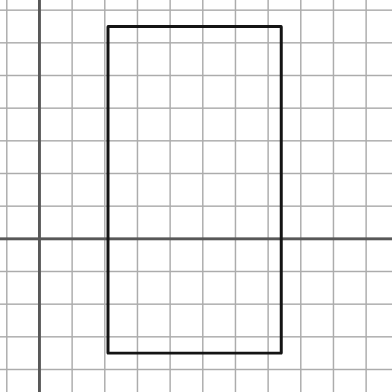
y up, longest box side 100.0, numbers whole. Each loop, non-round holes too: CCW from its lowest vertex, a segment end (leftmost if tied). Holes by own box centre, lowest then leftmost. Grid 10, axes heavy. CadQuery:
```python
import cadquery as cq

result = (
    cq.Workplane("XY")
    .moveTo(21.0, -35.0)
    .lineTo(74.0, -35.0)
    .lineTo(74.0, 65.0)
    .lineTo(21.0, 65.0)
    .close()
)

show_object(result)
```